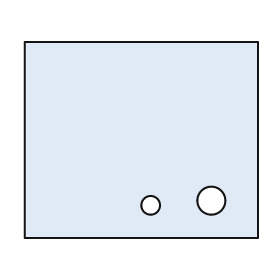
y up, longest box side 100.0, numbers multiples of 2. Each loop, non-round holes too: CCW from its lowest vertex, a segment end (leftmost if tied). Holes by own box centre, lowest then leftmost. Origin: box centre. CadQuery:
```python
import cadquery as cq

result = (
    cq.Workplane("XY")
    .moveTo(-50.0, -42.0)
    .lineTo(50.0, -42.0)
    .lineTo(50.0, 42.0)
    .lineTo(-50.0, 42.0)
    .close()
    .moveTo(4.0, -28.0)
    .circle(4.0)
    .moveTo(30.0, -26.0)
    .circle(6.0)
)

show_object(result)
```